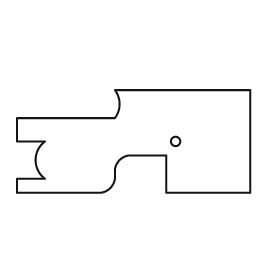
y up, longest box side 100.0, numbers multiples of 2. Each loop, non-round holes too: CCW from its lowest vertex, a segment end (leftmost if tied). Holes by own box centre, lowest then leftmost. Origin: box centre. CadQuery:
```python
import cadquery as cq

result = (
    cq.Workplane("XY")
    .moveTo(-50.0, -22.0)
    .lineTo(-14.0, -22.0)
    .threePointArc((-10.0, -20.0), (-8.0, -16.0))
    .lineTo(-8.0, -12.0)
    .threePointArc((-6.0, -8.0), (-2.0, -6.0))
    .lineTo(14.0, -6.0)
    .lineTo(14.0, -22.0)
    .lineTo(50.0, -22.0)
    .lineTo(50.0, 22.0)
    .lineTo(-8.0, 22.0)
    .threePointArc((-6.0, 16.0), (-8.0, 10.0))
    .lineTo(-50.0, 10.0)
    .lineTo(-50.0, 0.0)
    .lineTo(-38.0, 0.0)
    .threePointArc((-42.0, -8.0), (-38.0, -16.0))
    .lineTo(-50.0, -16.0)
    .close()
    .moveTo(18.0, 0.0)
    .circle(2.0)
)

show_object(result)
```